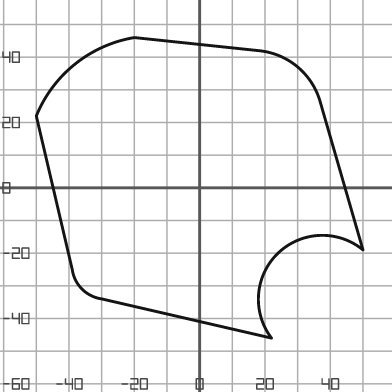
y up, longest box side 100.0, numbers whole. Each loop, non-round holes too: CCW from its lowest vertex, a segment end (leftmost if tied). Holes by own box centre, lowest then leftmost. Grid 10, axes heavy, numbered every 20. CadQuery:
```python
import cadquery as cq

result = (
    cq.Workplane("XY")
    .moveTo(22.0, -46.0)
    .threePointArc((24.0, -20.0), (50.0, -19.0))
    .lineTo(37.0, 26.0)
    .threePointArc((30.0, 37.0), (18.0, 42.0))
    .lineTo(-20.0, 46.0)
    .threePointArc((-38.0, 38.0), (-50.0, 22.0))
    .lineTo(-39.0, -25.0)
    .threePointArc((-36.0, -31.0), (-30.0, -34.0))
    .close()
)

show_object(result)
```